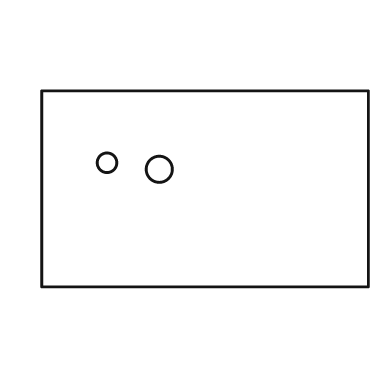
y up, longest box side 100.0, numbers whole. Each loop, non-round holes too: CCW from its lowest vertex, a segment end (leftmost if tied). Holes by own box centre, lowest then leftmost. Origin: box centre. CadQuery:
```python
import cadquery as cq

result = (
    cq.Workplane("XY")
    .moveTo(-50.0, -30.0)
    .lineTo(50.0, -30.0)
    .lineTo(50.0, 30.0)
    .lineTo(-50.0, 30.0)
    .close()
    .moveTo(-14.0, 6.0)
    .circle(4.0)
    .moveTo(-30.0, 8.0)
    .circle(3.0)
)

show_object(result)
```